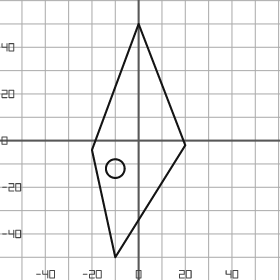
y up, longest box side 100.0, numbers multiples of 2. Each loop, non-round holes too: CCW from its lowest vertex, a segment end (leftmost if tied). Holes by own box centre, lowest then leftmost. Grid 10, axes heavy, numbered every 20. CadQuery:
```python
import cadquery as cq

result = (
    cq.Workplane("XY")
    .moveTo(-10.0, -50.0)
    .lineTo(20.0, -2.0)
    .lineTo(0.0, 50.0)
    .lineTo(-20.0, -4.0)
    .close()
    .moveTo(-10.0, -12.0)
    .circle(4.0)
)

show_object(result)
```